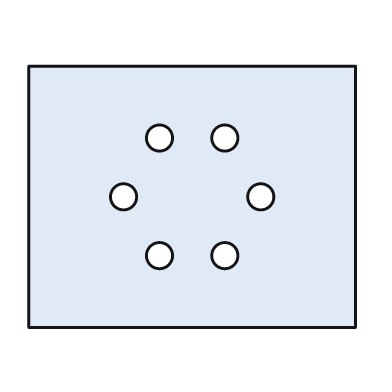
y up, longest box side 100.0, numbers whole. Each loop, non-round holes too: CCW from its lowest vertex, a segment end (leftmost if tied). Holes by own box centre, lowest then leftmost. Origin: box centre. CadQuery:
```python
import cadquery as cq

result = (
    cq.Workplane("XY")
    .moveTo(-50.0, -40.0)
    .lineTo(50.0, -40.0)
    .lineTo(50.0, 40.0)
    .lineTo(-50.0, 40.0)
    .close()
    .moveTo(-10.0, -18.0)
    .circle(4.0)
    .moveTo(10.0, -18.0)
    .circle(4.0)
    .moveTo(-21.0, 0.0)
    .circle(4.0)
    .moveTo(21.0, 0.0)
    .circle(4.0)
    .moveTo(-10.0, 18.0)
    .circle(4.0)
    .moveTo(10.0, 18.0)
    .circle(4.0)
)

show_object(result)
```